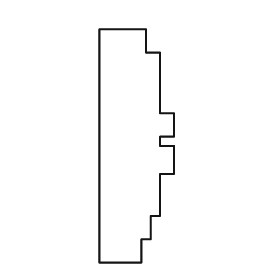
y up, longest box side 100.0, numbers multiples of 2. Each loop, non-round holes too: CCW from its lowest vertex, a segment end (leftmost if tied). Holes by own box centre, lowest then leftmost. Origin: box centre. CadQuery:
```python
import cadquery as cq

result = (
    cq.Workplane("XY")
    .moveTo(-16.0, -50.0)
    .lineTo(2.0, -50.0)
    .lineTo(2.0, -40.0)
    .lineTo(6.0, -40.0)
    .lineTo(6.0, -30.0)
    .lineTo(10.0, -30.0)
    .lineTo(10.0, -12.0)
    .lineTo(16.0, -12.0)
    .lineTo(16.0, 0.0)
    .lineTo(10.0, 0.0)
    .lineTo(10.0, 4.0)
    .lineTo(16.0, 4.0)
    .lineTo(16.0, 14.0)
    .lineTo(10.0, 14.0)
    .lineTo(10.0, 40.0)
    .lineTo(4.0, 40.0)
    .lineTo(4.0, 50.0)
    .lineTo(-16.0, 50.0)
    .close()
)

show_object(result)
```